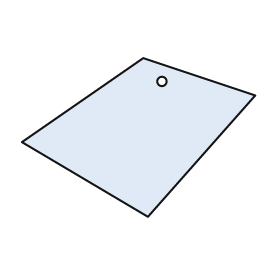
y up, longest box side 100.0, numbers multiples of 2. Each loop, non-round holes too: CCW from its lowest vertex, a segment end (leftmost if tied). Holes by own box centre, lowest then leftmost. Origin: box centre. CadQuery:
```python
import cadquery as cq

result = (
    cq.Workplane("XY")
    .moveTo(4.0, -34.0)
    .lineTo(50.0, 18.0)
    .lineTo(2.0, 34.0)
    .lineTo(-50.0, -2.0)
    .close()
    .moveTo(10.0, 24.0)
    .circle(2.0)
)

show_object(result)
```